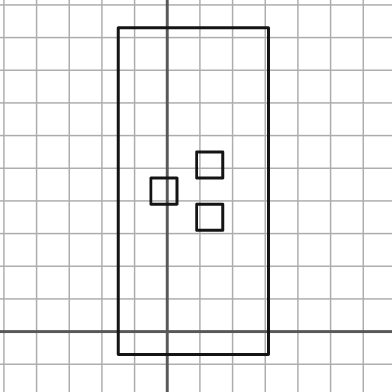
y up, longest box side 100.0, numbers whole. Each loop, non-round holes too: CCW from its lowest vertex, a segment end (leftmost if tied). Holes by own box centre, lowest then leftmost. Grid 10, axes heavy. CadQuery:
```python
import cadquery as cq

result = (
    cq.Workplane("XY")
    .moveTo(-15.0, -7.0)
    .lineTo(31.0, -7.0)
    .lineTo(31.0, 93.0)
    .lineTo(-15.0, 93.0)
    .close()
    .moveTo(9.0, 31.0)
    .lineTo(17.0, 31.0)
    .lineTo(17.0, 39.0)
    .lineTo(9.0, 39.0)
    .close()
    .moveTo(-5.0, 39.0)
    .lineTo(3.0, 39.0)
    .lineTo(3.0, 47.0)
    .lineTo(-5.0, 47.0)
    .close()
    .moveTo(9.0, 47.0)
    .lineTo(17.0, 47.0)
    .lineTo(17.0, 55.0)
    .lineTo(9.0, 55.0)
    .close()
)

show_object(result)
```